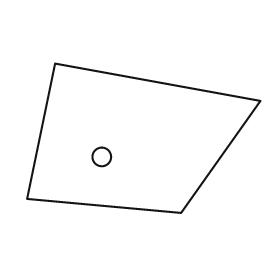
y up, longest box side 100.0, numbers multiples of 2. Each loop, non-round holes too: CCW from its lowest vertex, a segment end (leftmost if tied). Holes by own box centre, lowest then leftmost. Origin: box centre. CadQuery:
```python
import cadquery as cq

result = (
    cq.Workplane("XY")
    .moveTo(16.0, -32.0)
    .lineTo(50.0, 16.0)
    .lineTo(-38.0, 32.0)
    .lineTo(-50.0, -26.0)
    .close()
    .moveTo(-18.0, -8.0)
    .circle(4.0)
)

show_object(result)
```